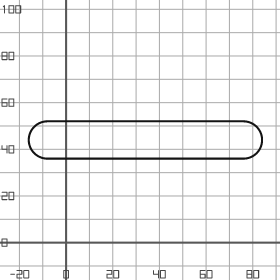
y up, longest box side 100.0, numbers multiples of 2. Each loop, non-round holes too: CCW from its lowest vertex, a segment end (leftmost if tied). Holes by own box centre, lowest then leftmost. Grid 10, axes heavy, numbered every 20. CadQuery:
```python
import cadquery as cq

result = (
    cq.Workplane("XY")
    .moveTo(-8.0, 36.0)
    .lineTo(76.0, 36.0)
    .threePointArc((84.0, 44.0), (76.0, 52.0))
    .lineTo(-8.0, 52.0)
    .threePointArc((-16.0, 44.0), (-8.0, 36.0))
    .close()
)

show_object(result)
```